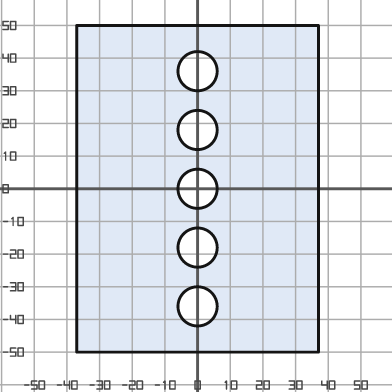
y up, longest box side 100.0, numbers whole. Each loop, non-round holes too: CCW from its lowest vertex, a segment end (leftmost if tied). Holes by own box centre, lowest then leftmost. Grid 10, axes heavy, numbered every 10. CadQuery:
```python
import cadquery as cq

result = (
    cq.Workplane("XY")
    .moveTo(-37.0, -50.0)
    .lineTo(37.0, -50.0)
    .lineTo(37.0, 50.0)
    .lineTo(-37.0, 50.0)
    .close()
    .moveTo(0.0, -36.0)
    .circle(6.0)
    .moveTo(0.0, -18.0)
    .circle(6.0)
    .moveTo(0.0, 0.0)
    .circle(6.0)
    .moveTo(0.0, 18.0)
    .circle(6.0)
    .moveTo(0.0, 36.0)
    .circle(6.0)
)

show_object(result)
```